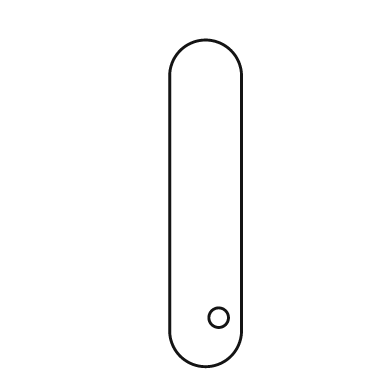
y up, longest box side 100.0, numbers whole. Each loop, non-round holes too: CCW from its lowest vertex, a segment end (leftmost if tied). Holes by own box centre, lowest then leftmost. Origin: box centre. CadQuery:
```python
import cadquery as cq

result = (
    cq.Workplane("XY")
    .moveTo(-11.0, -39.0)
    .threePointArc((0.0, -50.0), (11.0, -39.0))
    .lineTo(11.0, 39.0)
    .threePointArc((0.0, 50.0), (-11.0, 39.0))
    .close()
    .moveTo(4.0, -35.0)
    .circle(3.0)
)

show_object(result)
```